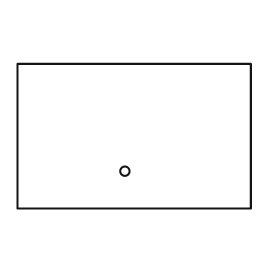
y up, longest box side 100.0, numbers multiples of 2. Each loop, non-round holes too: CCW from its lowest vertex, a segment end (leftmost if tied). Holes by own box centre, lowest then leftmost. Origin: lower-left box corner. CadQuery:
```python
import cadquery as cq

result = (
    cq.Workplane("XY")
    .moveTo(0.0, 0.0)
    .lineTo(100.0, 0.0)
    .lineTo(100.0, 62.0)
    .lineTo(0.0, 62.0)
    .close()
    .moveTo(46.0, 16.0)
    .circle(2.0)
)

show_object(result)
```